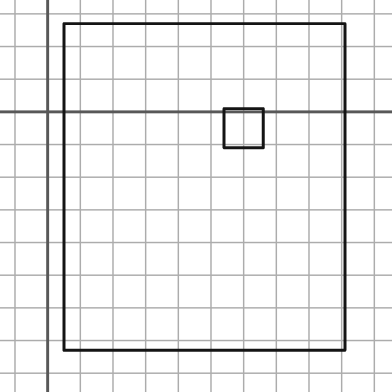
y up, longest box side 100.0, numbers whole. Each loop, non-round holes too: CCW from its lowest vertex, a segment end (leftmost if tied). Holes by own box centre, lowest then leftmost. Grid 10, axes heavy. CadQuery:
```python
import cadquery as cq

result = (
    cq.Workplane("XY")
    .moveTo(5.0, -73.0)
    .lineTo(91.0, -73.0)
    .lineTo(91.0, 27.0)
    .lineTo(5.0, 27.0)
    .close()
    .moveTo(54.0, -11.0)
    .lineTo(66.0, -11.0)
    .lineTo(66.0, 1.0)
    .lineTo(54.0, 1.0)
    .close()
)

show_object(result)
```